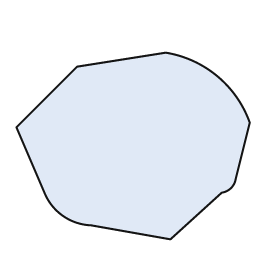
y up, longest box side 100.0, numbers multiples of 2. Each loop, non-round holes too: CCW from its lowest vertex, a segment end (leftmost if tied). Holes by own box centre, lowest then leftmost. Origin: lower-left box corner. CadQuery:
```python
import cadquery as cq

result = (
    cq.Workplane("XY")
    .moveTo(66.0, 0.0)
    .lineTo(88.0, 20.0)
    .threePointArc((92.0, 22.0), (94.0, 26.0))
    .lineTo(100.0, 50.0)
    .threePointArc((86.0, 70.0), (64.0, 80.0))
    .lineTo(26.0, 74.0)
    .lineTo(0.0, 48.0)
    .lineTo(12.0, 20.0)
    .threePointArc((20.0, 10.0), (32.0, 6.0))
    .close()
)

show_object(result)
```